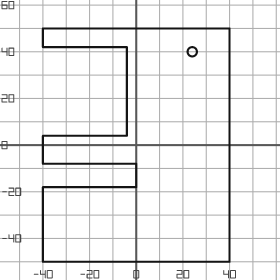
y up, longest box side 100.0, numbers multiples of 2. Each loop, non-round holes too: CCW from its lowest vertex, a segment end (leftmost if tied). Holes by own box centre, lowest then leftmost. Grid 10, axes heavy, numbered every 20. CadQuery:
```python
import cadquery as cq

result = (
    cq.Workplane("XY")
    .moveTo(-40.0, -50.0)
    .lineTo(40.0, -50.0)
    .lineTo(40.0, 50.0)
    .lineTo(-40.0, 50.0)
    .lineTo(-40.0, 42.0)
    .lineTo(-4.0, 42.0)
    .lineTo(-4.0, 4.0)
    .lineTo(-40.0, 4.0)
    .lineTo(-40.0, -8.0)
    .lineTo(0.0, -8.0)
    .lineTo(0.0, -18.0)
    .lineTo(-40.0, -18.0)
    .close()
    .moveTo(24.0, 40.0)
    .circle(2.0)
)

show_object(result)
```